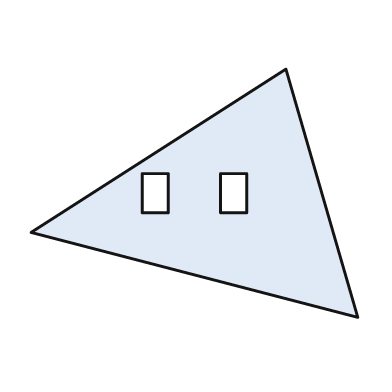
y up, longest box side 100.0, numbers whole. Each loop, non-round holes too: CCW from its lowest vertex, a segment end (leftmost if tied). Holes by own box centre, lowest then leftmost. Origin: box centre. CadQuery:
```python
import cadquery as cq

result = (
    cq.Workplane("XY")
    .moveTo(50.0, -38.0)
    .lineTo(28.0, 38.0)
    .lineTo(-50.0, -12.0)
    .close()
    .moveTo(-16.0, -6.0)
    .lineTo(-8.0, -6.0)
    .lineTo(-8.0, 6.0)
    .lineTo(-16.0, 6.0)
    .close()
    .moveTo(8.0, -6.0)
    .lineTo(16.0, -6.0)
    .lineTo(16.0, 6.0)
    .lineTo(8.0, 6.0)
    .close()
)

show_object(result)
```